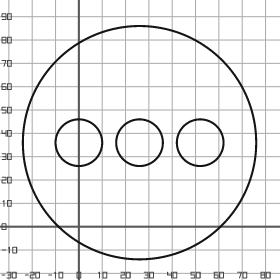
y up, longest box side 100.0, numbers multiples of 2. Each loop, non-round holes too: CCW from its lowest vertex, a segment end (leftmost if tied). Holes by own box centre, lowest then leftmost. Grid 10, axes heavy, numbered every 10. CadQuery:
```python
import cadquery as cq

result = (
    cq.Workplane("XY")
    .moveTo(26.0, 36.0)
    .circle(50.0)
    .moveTo(0.0, 36.0)
    .circle(10.0)
    .moveTo(26.0, 36.0)
    .circle(10.0)
    .moveTo(52.0, 36.0)
    .circle(10.0)
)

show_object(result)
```